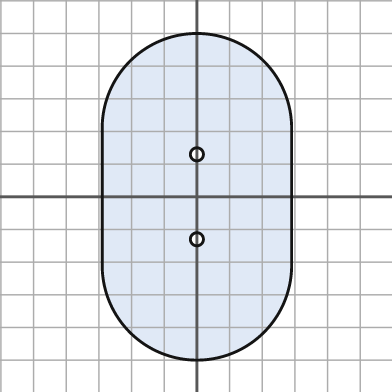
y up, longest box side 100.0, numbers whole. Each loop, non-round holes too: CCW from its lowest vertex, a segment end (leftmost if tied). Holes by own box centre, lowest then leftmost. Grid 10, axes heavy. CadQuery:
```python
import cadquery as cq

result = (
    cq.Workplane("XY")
    .moveTo(-29.0, -21.0)
    .threePointArc((0.0, -50.0), (29.0, -21.0))
    .lineTo(29.0, 21.0)
    .threePointArc((0.0, 50.0), (-29.0, 21.0))
    .close()
    .moveTo(0.0, -13.0)
    .circle(2.0)
    .moveTo(0.0, 13.0)
    .circle(2.0)
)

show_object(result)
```